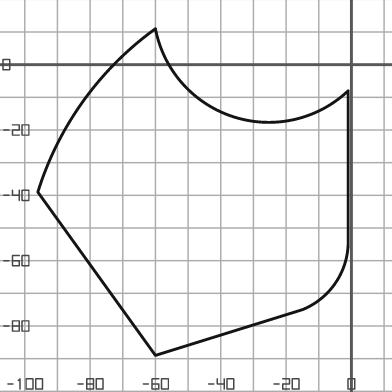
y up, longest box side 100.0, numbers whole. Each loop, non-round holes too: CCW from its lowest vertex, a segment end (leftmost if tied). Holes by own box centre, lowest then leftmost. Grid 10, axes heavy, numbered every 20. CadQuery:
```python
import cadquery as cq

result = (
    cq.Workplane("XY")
    .moveTo(-60.0, -89.0)
    .lineTo(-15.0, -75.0)
    .threePointArc((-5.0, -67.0), (-1.0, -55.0))
    .lineTo(-1.0, -8.0)
    .threePointArc((-36.0, -16.0), (-60.0, 11.0))
    .threePointArc((-82.0, -11.0), (-96.0, -39.0))
    .close()
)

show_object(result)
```